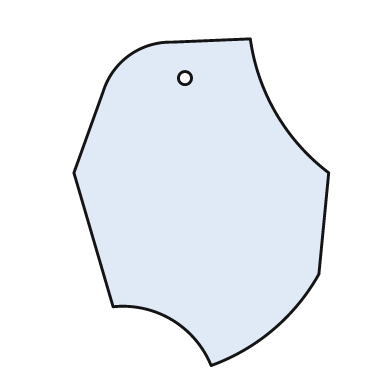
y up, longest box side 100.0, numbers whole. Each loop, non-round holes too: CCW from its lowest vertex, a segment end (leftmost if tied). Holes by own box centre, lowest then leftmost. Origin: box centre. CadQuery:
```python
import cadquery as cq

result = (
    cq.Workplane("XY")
    .moveTo(3.0, -50.0)
    .threePointArc((22.0, -39.0), (36.0, -22.0))
    .lineTo(39.0, 9.0)
    .threePointArc((23.0, 27.0), (15.0, 50.0))
    .lineTo(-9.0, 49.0)
    .threePointArc((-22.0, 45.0), (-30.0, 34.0))
    .lineTo(-39.0, 9.0)
    .lineTo(-27.0, -32.0)
    .threePointArc((-9.0, -36.0), (3.0, -50.0))
    .close()
    .moveTo(-5.0, 38.0)
    .circle(2.0)
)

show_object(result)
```